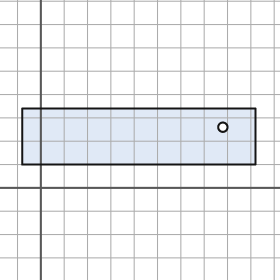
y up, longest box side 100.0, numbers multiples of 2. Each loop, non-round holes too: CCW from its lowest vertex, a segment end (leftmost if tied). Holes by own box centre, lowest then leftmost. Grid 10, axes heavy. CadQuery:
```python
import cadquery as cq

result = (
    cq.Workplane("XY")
    .moveTo(-8.0, 10.0)
    .lineTo(92.0, 10.0)
    .lineTo(92.0, 34.0)
    .lineTo(-8.0, 34.0)
    .close()
    .moveTo(78.0, 26.0)
    .circle(2.0)
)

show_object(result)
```